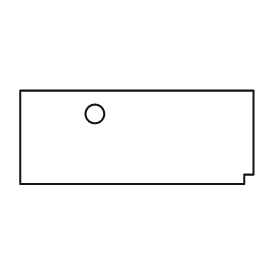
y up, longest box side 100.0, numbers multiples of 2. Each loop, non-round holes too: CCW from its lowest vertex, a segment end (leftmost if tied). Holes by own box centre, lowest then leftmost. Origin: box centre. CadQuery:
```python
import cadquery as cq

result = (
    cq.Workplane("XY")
    .moveTo(-50.0, -20.0)
    .lineTo(46.0, -20.0)
    .lineTo(46.0, -16.0)
    .lineTo(50.0, -16.0)
    .lineTo(50.0, 20.0)
    .lineTo(-50.0, 20.0)
    .close()
    .moveTo(-18.0, 10.0)
    .circle(4.0)
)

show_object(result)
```